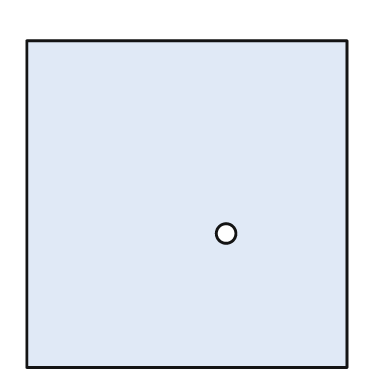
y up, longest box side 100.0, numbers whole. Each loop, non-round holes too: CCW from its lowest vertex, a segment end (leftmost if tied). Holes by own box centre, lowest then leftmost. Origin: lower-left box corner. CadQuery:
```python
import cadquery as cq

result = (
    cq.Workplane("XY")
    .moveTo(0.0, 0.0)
    .lineTo(98.0, 0.0)
    .lineTo(98.0, 100.0)
    .lineTo(0.0, 100.0)
    .close()
    .moveTo(61.0, 41.0)
    .circle(3.0)
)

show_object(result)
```